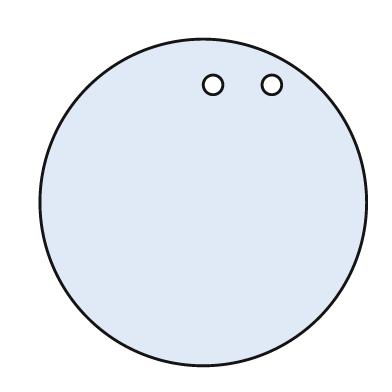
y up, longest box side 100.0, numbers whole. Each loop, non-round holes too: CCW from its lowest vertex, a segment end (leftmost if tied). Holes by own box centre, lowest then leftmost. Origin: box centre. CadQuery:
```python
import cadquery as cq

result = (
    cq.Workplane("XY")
    .moveTo(0.0, 0.0)
    .circle(50.0)
    .moveTo(3.0, 36.0)
    .circle(3.0)
    .moveTo(21.0, 36.0)
    .circle(3.0)
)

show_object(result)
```